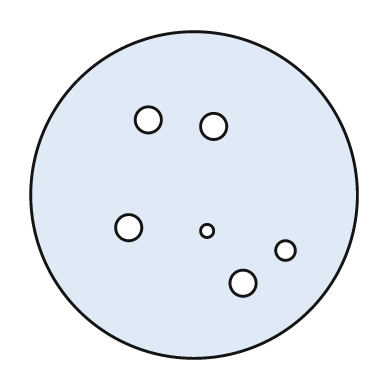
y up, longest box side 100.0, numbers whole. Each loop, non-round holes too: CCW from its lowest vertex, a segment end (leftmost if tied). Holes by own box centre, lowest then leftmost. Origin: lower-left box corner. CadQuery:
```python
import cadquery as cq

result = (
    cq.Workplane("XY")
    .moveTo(50.0, 50.0)
    .circle(50.0)
    .moveTo(65.0, 23.0)
    .circle(4.0)
    .moveTo(78.0, 33.0)
    .circle(3.0)
    .moveTo(54.0, 39.0)
    .circle(2.0)
    .moveTo(30.0, 40.0)
    .circle(4.0)
    .moveTo(56.0, 71.0)
    .circle(4.0)
    .moveTo(36.0, 73.0)
    .circle(4.0)
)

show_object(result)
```